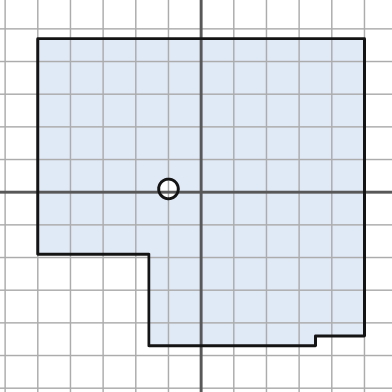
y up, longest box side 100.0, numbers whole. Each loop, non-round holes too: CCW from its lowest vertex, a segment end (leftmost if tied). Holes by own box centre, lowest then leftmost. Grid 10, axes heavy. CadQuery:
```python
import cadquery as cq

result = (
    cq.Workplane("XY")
    .moveTo(-16.0, -47.0)
    .lineTo(35.0, -47.0)
    .lineTo(35.0, -44.0)
    .lineTo(50.0, -44.0)
    .lineTo(50.0, 47.0)
    .lineTo(-50.0, 47.0)
    .lineTo(-50.0, -19.0)
    .lineTo(-16.0, -19.0)
    .close()
    .moveTo(-10.0, 1.0)
    .circle(3.0)
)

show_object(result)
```